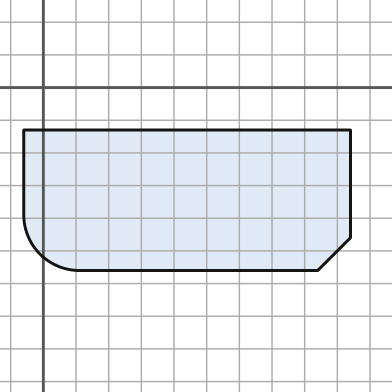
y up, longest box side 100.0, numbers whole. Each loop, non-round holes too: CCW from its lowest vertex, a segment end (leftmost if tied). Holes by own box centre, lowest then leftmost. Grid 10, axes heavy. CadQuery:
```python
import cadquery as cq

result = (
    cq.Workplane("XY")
    .moveTo(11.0, -56.0)
    .lineTo(84.0, -56.0)
    .lineTo(94.0, -46.0)
    .lineTo(94.0, -13.0)
    .lineTo(-6.0, -13.0)
    .lineTo(-6.0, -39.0)
    .threePointArc((-1.0, -51.0), (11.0, -56.0))
    .close()
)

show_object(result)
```